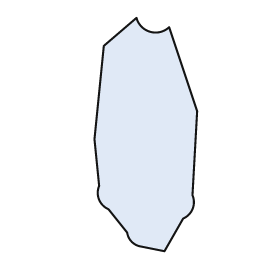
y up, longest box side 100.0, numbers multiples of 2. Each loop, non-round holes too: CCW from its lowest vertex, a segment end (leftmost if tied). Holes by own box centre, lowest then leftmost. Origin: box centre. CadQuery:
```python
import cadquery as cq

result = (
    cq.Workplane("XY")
    .moveTo(8.0, -50.0)
    .lineTo(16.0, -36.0)
    .threePointArc((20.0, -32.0), (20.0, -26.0))
    .lineTo(22.0, 10.0)
    .lineTo(10.0, 46.0)
    .threePointArc((2.0, 44.0), (-4.0, 50.0))
    .lineTo(-18.0, 38.0)
    .lineTo(-22.0, -2.0)
    .lineTo(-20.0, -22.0)
    .threePointArc((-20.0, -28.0), (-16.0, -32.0))
    .lineTo(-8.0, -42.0)
    .threePointArc((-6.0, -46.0), (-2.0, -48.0))
    .close()
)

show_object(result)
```